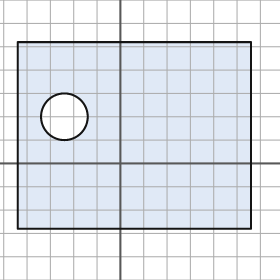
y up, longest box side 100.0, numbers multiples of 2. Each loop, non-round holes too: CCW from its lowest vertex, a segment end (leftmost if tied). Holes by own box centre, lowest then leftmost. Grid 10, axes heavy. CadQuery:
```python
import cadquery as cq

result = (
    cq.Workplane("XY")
    .moveTo(-44.0, -28.0)
    .lineTo(56.0, -28.0)
    .lineTo(56.0, 52.0)
    .lineTo(-44.0, 52.0)
    .close()
    .moveTo(-24.0, 20.0)
    .circle(10.0)
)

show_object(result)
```